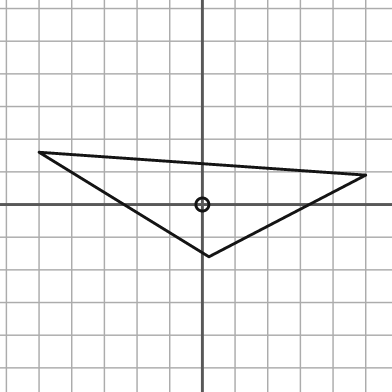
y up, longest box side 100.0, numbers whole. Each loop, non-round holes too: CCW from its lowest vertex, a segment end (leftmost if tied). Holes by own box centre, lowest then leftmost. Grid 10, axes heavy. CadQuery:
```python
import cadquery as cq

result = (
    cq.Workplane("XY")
    .moveTo(2.0, -16.0)
    .lineTo(50.0, 9.0)
    .lineTo(-50.0, 16.0)
    .close()
    .moveTo(0.0, 0.0)
    .circle(2.0)
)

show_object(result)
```